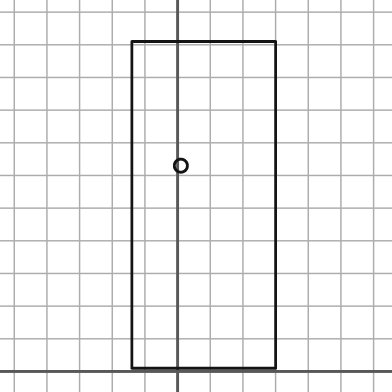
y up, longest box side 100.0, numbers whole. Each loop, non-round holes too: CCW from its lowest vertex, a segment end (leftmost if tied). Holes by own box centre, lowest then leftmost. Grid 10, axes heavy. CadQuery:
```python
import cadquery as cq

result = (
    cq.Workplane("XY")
    .moveTo(-14.0, 1.0)
    .lineTo(30.0, 1.0)
    .lineTo(30.0, 101.0)
    .lineTo(-14.0, 101.0)
    .close()
    .moveTo(1.0, 63.0)
    .circle(2.0)
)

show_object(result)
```